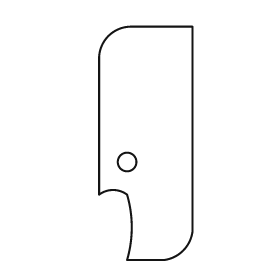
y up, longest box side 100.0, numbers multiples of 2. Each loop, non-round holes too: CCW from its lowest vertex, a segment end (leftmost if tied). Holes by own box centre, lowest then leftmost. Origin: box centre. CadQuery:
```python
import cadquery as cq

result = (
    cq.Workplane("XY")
    .moveTo(-8.0, -50.0)
    .lineTo(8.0, -50.0)
    .threePointArc((16.0, -46.0), (20.0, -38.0))
    .lineTo(20.0, 50.0)
    .lineTo(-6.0, 50.0)
    .threePointArc((-16.0, 46.0), (-20.0, 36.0))
    .lineTo(-20.0, -22.0)
    .threePointArc((-14.0, -20.0), (-8.0, -22.0))
    .threePointArc((-6.0, -36.0), (-8.0, -50.0))
    .close()
    .moveTo(-8.0, -8.0)
    .circle(4.0)
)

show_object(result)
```